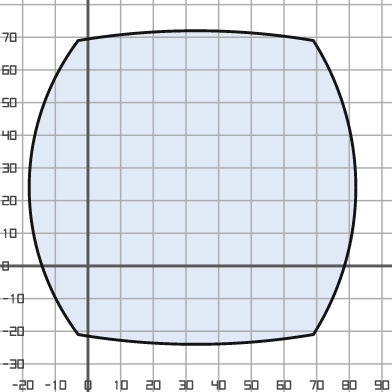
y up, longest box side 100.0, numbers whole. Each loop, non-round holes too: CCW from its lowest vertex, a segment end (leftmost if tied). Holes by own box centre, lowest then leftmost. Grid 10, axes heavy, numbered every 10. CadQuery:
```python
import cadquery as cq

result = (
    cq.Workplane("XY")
    .moveTo(-3.0, -21.0)
    .threePointArc((33.0, -24.0), (69.0, -21.0))
    .threePointArc((82.0, 24.0), (69.0, 69.0))
    .threePointArc((33.0, 72.0), (-3.0, 69.0))
    .threePointArc((-18.0, 24.0), (-3.0, -21.0))
    .close()
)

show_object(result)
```